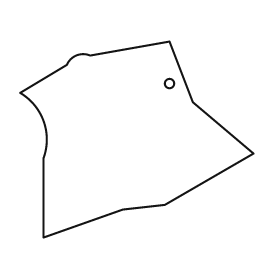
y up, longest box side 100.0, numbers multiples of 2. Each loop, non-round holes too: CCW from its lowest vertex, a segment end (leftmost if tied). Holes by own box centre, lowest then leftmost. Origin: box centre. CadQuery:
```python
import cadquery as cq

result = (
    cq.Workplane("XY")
    .moveTo(-40.0, -42.0)
    .lineTo(-6.0, -30.0)
    .lineTo(12.0, -28.0)
    .lineTo(50.0, -6.0)
    .lineTo(24.0, 16.0)
    .lineTo(14.0, 42.0)
    .lineTo(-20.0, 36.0)
    .threePointArc((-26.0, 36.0), (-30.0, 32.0))
    .lineTo(-50.0, 20.0)
    .threePointArc((-40.0, 8.0), (-40.0, -8.0))
    .close()
    .moveTo(14.0, 24.0)
    .circle(2.0)
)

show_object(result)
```